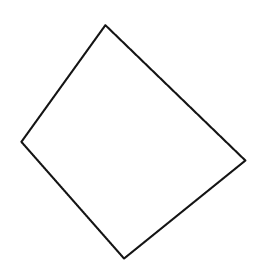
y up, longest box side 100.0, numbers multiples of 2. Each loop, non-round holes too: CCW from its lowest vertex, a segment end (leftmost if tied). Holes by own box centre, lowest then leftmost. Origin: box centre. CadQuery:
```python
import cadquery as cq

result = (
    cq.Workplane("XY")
    .moveTo(-4.0, -50.0)
    .lineTo(48.0, -8.0)
    .lineTo(-12.0, 50.0)
    .lineTo(-48.0, 0.0)
    .close()
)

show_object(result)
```